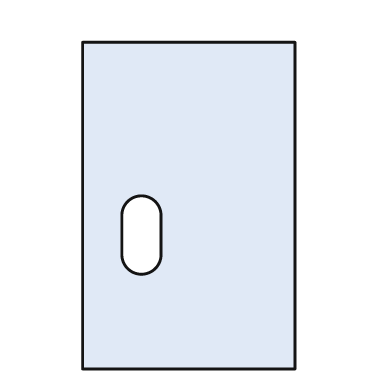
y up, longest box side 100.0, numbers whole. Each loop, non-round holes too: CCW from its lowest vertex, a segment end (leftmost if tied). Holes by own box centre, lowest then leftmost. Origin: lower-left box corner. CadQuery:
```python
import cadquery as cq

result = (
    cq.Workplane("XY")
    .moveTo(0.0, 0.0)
    .lineTo(65.0, 0.0)
    .lineTo(65.0, 100.0)
    .lineTo(0.0, 100.0)
    .close()
    .moveTo(12.0, 35.0)
    .threePointArc((18.0, 29.0), (24.0, 35.0))
    .lineTo(24.0, 47.0)
    .threePointArc((18.0, 53.0), (12.0, 47.0))
    .close()
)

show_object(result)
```